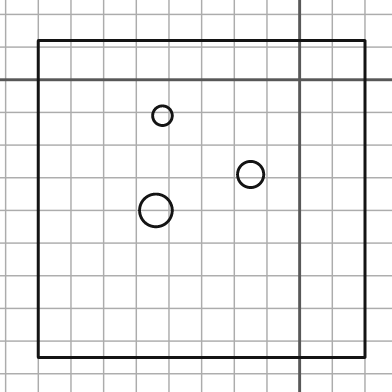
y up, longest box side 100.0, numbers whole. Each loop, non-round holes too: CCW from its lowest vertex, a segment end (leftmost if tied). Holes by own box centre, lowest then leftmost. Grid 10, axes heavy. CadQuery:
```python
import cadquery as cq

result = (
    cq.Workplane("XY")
    .moveTo(-80.0, -85.0)
    .lineTo(20.0, -85.0)
    .lineTo(20.0, 12.0)
    .lineTo(-80.0, 12.0)
    .close()
    .moveTo(-44.0, -40.0)
    .circle(5.0)
    .moveTo(-15.0, -29.0)
    .circle(4.0)
    .moveTo(-42.0, -11.0)
    .circle(3.0)
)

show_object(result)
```